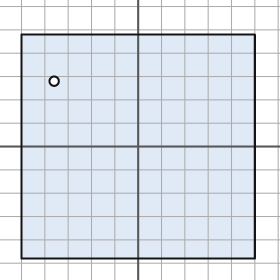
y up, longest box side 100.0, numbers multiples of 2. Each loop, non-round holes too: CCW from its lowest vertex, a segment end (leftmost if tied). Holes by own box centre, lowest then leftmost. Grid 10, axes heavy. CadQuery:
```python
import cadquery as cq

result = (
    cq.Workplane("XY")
    .moveTo(-50.0, -48.0)
    .lineTo(50.0, -48.0)
    .lineTo(50.0, 48.0)
    .lineTo(-50.0, 48.0)
    .close()
    .moveTo(-36.0, 28.0)
    .circle(2.0)
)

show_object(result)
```